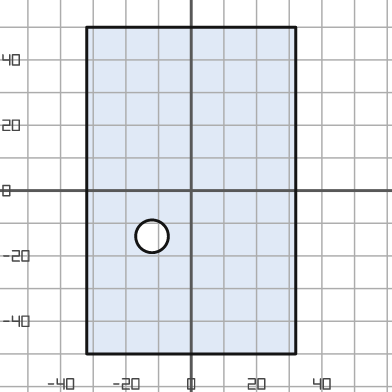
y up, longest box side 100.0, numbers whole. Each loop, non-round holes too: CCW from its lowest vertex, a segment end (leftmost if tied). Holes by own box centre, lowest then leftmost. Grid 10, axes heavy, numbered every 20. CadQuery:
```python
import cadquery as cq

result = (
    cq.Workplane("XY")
    .moveTo(-32.0, -50.0)
    .lineTo(32.0, -50.0)
    .lineTo(32.0, 50.0)
    .lineTo(-32.0, 50.0)
    .close()
    .moveTo(-12.0, -14.0)
    .circle(5.0)
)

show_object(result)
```